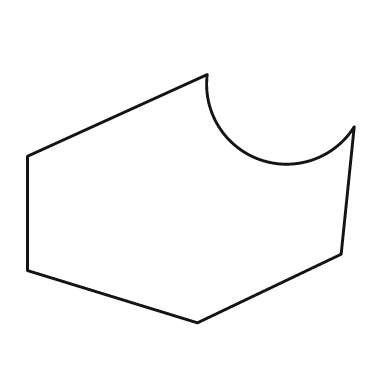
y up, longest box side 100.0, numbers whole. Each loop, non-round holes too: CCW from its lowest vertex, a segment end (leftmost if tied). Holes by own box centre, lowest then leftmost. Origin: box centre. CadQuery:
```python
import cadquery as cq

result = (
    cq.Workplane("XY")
    .moveTo(2.0, -38.0)
    .lineTo(46.0, -17.0)
    .lineTo(50.0, 22.0)
    .threePointArc((21.0, 12.0), (5.0, 38.0))
    .lineTo(-50.0, 13.0)
    .lineTo(-50.0, -22.0)
    .close()
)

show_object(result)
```